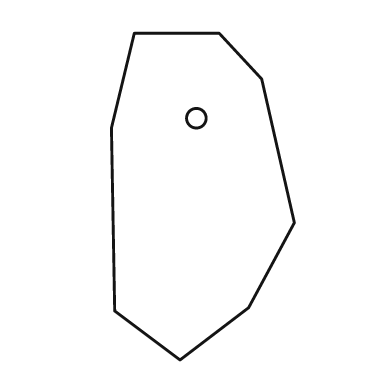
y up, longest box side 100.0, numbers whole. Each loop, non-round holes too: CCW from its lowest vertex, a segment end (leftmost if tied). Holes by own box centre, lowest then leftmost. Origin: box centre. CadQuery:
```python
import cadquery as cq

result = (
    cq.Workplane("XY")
    .moveTo(-7.0, -50.0)
    .lineTo(14.0, -34.0)
    .lineTo(28.0, -8.0)
    .lineTo(18.0, 36.0)
    .lineTo(5.0, 50.0)
    .lineTo(-21.0, 50.0)
    .lineTo(-28.0, 21.0)
    .lineTo(-27.0, -35.0)
    .close()
    .moveTo(-2.0, 24.0)
    .circle(3.0)
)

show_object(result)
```